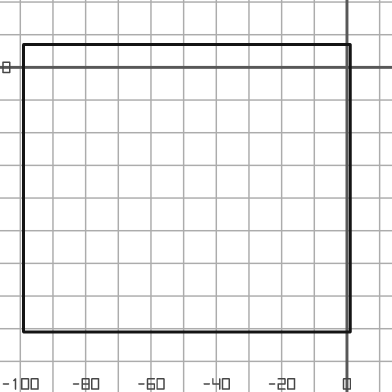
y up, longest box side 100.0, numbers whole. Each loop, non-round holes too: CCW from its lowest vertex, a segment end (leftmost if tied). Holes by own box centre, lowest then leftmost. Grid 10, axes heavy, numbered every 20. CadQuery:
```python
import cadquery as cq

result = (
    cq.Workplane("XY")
    .moveTo(-99.0, -81.0)
    .lineTo(1.0, -81.0)
    .lineTo(1.0, 7.0)
    .lineTo(-99.0, 7.0)
    .close()
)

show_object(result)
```